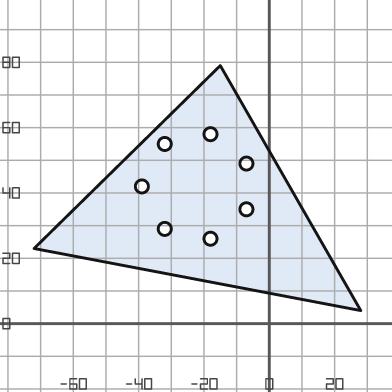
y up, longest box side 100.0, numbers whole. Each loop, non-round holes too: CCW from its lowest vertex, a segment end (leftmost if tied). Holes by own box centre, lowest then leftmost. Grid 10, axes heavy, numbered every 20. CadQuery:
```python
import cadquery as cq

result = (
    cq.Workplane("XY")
    .moveTo(28.0, 4.0)
    .lineTo(-15.0, 79.0)
    .lineTo(-72.0, 23.0)
    .close()
    .moveTo(-18.0, 26.0)
    .circle(2.0)
    .moveTo(-32.0, 29.0)
    .circle(2.0)
    .moveTo(-7.0, 35.0)
    .circle(2.0)
    .moveTo(-39.0, 42.0)
    .circle(2.0)
    .moveTo(-7.0, 49.0)
    .circle(2.0)
    .moveTo(-32.0, 55.0)
    .circle(2.0)
    .moveTo(-18.0, 58.0)
    .circle(2.0)
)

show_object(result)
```